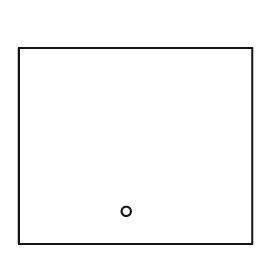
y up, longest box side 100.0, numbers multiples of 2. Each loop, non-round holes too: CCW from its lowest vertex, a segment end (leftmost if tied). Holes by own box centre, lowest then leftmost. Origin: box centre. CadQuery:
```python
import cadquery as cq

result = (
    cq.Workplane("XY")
    .moveTo(-50.0, -42.0)
    .lineTo(50.0, -42.0)
    .lineTo(50.0, 42.0)
    .lineTo(-50.0, 42.0)
    .close()
    .moveTo(-4.0, -28.0)
    .circle(2.0)
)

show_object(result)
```